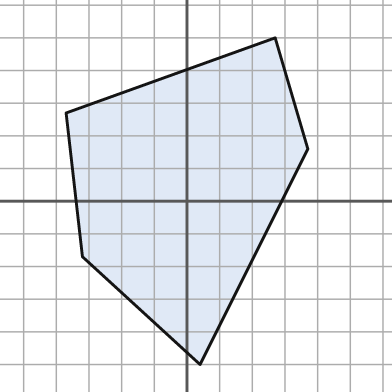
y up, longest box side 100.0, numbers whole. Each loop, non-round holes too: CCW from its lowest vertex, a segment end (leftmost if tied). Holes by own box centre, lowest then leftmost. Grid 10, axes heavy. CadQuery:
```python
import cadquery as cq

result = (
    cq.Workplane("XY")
    .moveTo(4.0, -50.0)
    .lineTo(37.0, 16.0)
    .lineTo(27.0, 50.0)
    .lineTo(-37.0, 27.0)
    .lineTo(-32.0, -17.0)
    .close()
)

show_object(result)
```